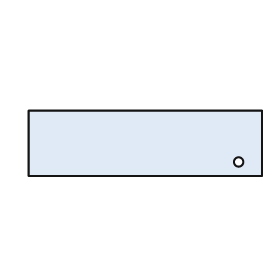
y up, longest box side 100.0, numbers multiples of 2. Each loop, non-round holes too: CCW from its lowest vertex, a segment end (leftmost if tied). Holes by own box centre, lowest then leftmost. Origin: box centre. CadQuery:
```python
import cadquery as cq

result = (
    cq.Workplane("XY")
    .moveTo(-50.0, -14.0)
    .lineTo(50.0, -14.0)
    .lineTo(50.0, 14.0)
    .lineTo(-50.0, 14.0)
    .close()
    .moveTo(40.0, -8.0)
    .circle(2.0)
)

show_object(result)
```